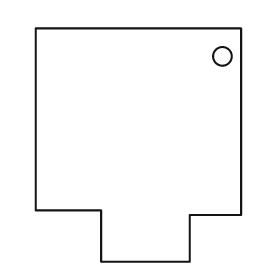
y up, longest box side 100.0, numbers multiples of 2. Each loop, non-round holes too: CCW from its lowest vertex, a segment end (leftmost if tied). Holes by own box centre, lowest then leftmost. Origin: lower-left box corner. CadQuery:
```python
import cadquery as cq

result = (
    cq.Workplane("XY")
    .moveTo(28.0, 0.0)
    .lineTo(66.0, 0.0)
    .lineTo(66.0, 20.0)
    .lineTo(88.0, 20.0)
    .lineTo(88.0, 100.0)
    .lineTo(0.0, 100.0)
    .lineTo(0.0, 22.0)
    .lineTo(28.0, 22.0)
    .close()
    .moveTo(80.0, 88.0)
    .circle(4.0)
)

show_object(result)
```